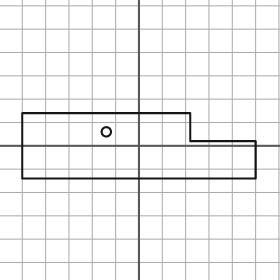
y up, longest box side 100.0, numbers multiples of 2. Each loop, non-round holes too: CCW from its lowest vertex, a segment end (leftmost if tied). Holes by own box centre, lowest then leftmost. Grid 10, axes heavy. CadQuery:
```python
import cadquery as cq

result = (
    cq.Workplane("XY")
    .moveTo(-50.0, -14.0)
    .lineTo(50.0, -14.0)
    .lineTo(50.0, 2.0)
    .lineTo(22.0, 2.0)
    .lineTo(22.0, 14.0)
    .lineTo(-50.0, 14.0)
    .close()
    .moveTo(-14.0, 6.0)
    .circle(2.0)
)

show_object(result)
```